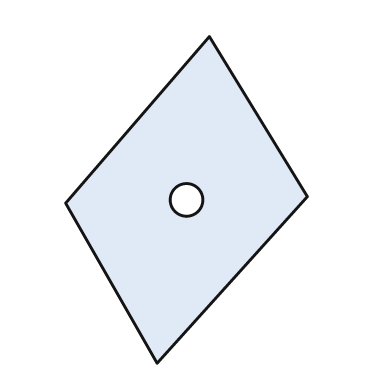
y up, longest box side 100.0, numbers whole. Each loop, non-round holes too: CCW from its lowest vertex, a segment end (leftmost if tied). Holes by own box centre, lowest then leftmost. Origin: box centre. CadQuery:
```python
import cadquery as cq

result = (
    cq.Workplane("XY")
    .moveTo(-9.0, -50.0)
    .lineTo(37.0, 1.0)
    .lineTo(7.0, 50.0)
    .lineTo(-37.0, -1.0)
    .close()
    .moveTo(0.0, 0.0)
    .circle(5.0)
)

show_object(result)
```